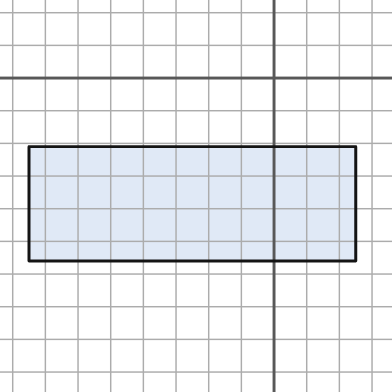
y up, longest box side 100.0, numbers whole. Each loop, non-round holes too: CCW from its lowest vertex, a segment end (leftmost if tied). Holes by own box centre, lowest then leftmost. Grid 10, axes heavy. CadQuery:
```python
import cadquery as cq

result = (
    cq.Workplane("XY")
    .moveTo(-75.0, -56.0)
    .lineTo(25.0, -56.0)
    .lineTo(25.0, -21.0)
    .lineTo(-75.0, -21.0)
    .close()
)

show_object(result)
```